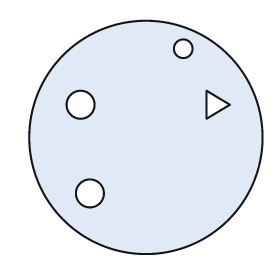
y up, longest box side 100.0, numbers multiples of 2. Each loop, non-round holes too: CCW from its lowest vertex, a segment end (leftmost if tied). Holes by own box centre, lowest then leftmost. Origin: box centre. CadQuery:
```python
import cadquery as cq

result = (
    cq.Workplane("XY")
    .moveTo(0.0, 0.0)
    .circle(50.0)
    .moveTo(-24.0, -24.0)
    .circle(6.0)
    .moveTo(-28.0, 14.0)
    .circle(6.0)
    .moveTo(26.0, 8.0)
    .lineTo(36.0, 14.0)
    .lineTo(26.0, 20.0)
    .close()
    .moveTo(16.0, 38.0)
    .circle(4.0)
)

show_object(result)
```